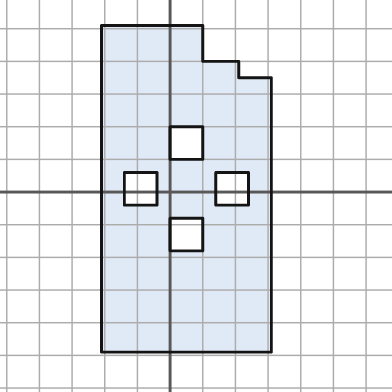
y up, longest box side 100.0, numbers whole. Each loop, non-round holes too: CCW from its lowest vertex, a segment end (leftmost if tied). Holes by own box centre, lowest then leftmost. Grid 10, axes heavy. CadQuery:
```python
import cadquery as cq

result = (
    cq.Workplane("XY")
    .moveTo(-21.0, -49.0)
    .lineTo(31.0, -49.0)
    .lineTo(31.0, 35.0)
    .lineTo(21.0, 35.0)
    .lineTo(21.0, 40.0)
    .lineTo(10.0, 40.0)
    .lineTo(10.0, 51.0)
    .lineTo(-21.0, 51.0)
    .close()
    .moveTo(0.0, -18.0)
    .lineTo(10.0, -18.0)
    .lineTo(10.0, -8.0)
    .lineTo(0.0, -8.0)
    .close()
    .moveTo(-14.0, -4.0)
    .lineTo(-4.0, -4.0)
    .lineTo(-4.0, 6.0)
    .lineTo(-14.0, 6.0)
    .close()
    .moveTo(14.0, -4.0)
    .lineTo(24.0, -4.0)
    .lineTo(24.0, 6.0)
    .lineTo(14.0, 6.0)
    .close()
    .moveTo(0.0, 10.0)
    .lineTo(10.0, 10.0)
    .lineTo(10.0, 20.0)
    .lineTo(0.0, 20.0)
    .close()
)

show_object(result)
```